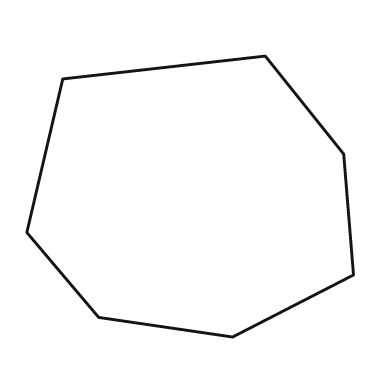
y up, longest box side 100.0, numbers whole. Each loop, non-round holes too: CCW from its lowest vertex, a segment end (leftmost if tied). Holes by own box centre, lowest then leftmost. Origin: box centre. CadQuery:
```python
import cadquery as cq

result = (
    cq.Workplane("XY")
    .moveTo(13.0, -43.0)
    .lineTo(50.0, -24.0)
    .lineTo(47.0, 13.0)
    .lineTo(23.0, 43.0)
    .lineTo(-39.0, 36.0)
    .lineTo(-50.0, -11.0)
    .lineTo(-28.0, -37.0)
    .close()
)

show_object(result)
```